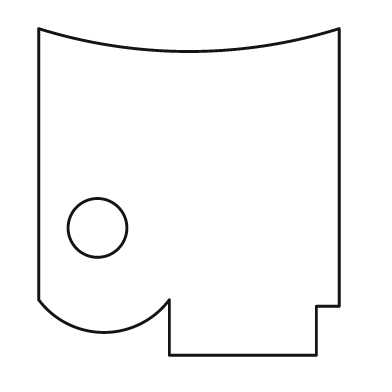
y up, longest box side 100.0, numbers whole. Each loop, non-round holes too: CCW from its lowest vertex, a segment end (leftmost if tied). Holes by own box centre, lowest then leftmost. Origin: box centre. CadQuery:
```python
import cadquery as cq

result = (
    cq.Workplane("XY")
    .moveTo(-6.0, -50.0)
    .lineTo(39.0, -50.0)
    .lineTo(39.0, -35.0)
    .lineTo(46.0, -35.0)
    .lineTo(46.0, 50.0)
    .threePointArc((0.0, 43.0), (-46.0, 50.0))
    .lineTo(-46.0, -33.0)
    .threePointArc((-26.0, -43.0), (-6.0, -33.0))
    .close()
    .moveTo(-28.0, -11.0)
    .circle(9.0)
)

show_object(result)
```